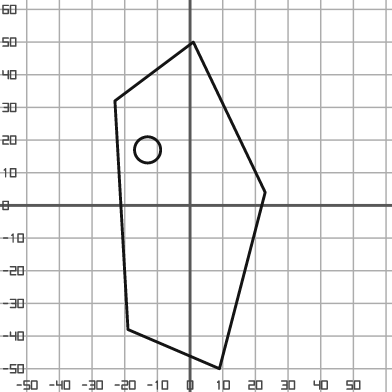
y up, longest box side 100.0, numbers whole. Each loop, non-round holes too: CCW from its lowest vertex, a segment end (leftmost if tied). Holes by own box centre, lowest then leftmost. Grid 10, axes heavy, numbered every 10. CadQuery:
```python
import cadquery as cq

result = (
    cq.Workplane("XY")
    .moveTo(9.0, -50.0)
    .lineTo(23.0, 4.0)
    .lineTo(1.0, 50.0)
    .lineTo(-23.0, 32.0)
    .lineTo(-19.0, -38.0)
    .close()
    .moveTo(-13.0, 17.0)
    .circle(4.0)
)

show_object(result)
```